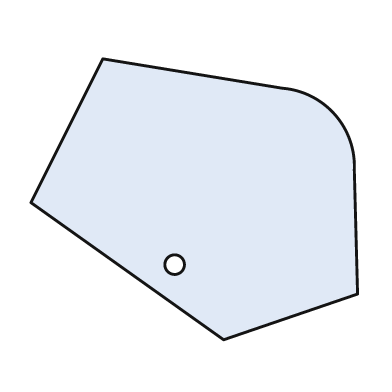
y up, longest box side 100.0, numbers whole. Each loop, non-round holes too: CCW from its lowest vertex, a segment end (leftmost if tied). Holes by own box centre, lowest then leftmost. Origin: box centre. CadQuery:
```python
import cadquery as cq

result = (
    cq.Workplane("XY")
    .moveTo(9.0, -43.0)
    .lineTo(50.0, -29.0)
    .lineTo(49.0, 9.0)
    .threePointArc((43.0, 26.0), (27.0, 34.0))
    .lineTo(-28.0, 43.0)
    .lineTo(-50.0, -1.0)
    .close()
    .moveTo(-6.0, -20.0)
    .circle(3.0)
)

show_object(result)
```